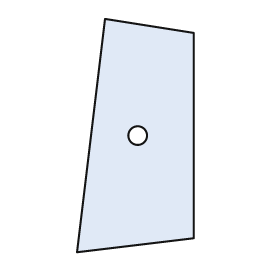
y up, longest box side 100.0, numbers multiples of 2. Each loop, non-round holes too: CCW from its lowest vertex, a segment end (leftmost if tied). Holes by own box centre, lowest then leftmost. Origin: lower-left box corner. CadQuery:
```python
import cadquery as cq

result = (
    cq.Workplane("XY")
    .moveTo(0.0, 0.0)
    .lineTo(50.0, 6.0)
    .lineTo(50.0, 94.0)
    .lineTo(12.0, 100.0)
    .close()
    .moveTo(26.0, 50.0)
    .circle(4.0)
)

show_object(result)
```